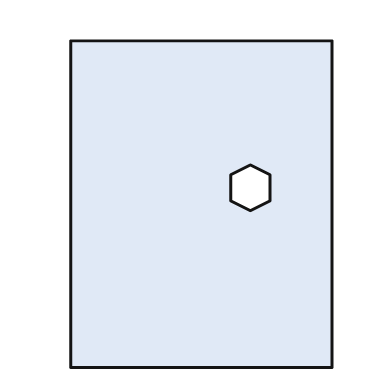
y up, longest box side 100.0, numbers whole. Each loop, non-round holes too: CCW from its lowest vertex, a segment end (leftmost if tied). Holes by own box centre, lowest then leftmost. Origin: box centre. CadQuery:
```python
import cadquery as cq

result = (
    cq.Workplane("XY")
    .moveTo(-40.0, -50.0)
    .lineTo(40.0, -50.0)
    .lineTo(40.0, 50.0)
    .lineTo(-40.0, 50.0)
    .close()
    .moveTo(15.0, -2.0)
    .lineTo(21.0, 1.0)
    .lineTo(21.0, 9.0)
    .lineTo(15.0, 12.0)
    .lineTo(9.0, 9.0)
    .lineTo(9.0, 1.0)
    .close()
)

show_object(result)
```